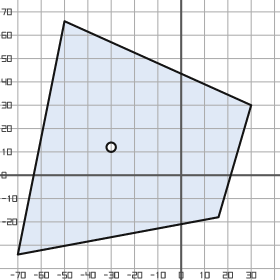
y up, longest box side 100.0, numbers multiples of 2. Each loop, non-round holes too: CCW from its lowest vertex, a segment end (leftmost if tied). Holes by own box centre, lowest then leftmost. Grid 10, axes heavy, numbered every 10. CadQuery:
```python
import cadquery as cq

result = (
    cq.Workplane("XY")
    .moveTo(-70.0, -34.0)
    .lineTo(16.0, -18.0)
    .lineTo(30.0, 30.0)
    .lineTo(-50.0, 66.0)
    .close()
    .moveTo(-30.0, 12.0)
    .circle(2.0)
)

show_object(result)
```